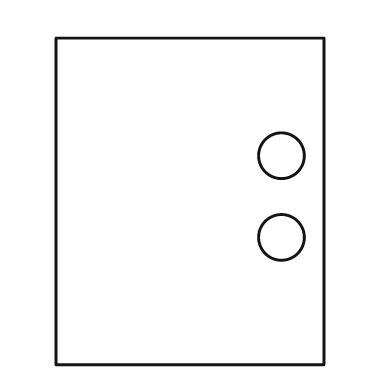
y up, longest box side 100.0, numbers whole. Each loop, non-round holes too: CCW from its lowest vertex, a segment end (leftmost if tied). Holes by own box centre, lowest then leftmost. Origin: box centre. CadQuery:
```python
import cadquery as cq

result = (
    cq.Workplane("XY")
    .moveTo(-41.0, -50.0)
    .lineTo(41.0, -50.0)
    .lineTo(41.0, 50.0)
    .lineTo(-41.0, 50.0)
    .close()
    .moveTo(28.0, -11.0)
    .circle(7.0)
    .moveTo(28.0, 14.0)
    .circle(7.0)
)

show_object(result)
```